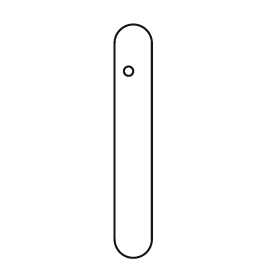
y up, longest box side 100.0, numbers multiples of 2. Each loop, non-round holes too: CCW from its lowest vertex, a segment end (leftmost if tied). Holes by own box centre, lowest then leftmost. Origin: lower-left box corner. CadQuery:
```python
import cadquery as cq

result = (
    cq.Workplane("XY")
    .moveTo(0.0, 8.0)
    .threePointArc((8.0, 0.0), (16.0, 8.0))
    .lineTo(16.0, 92.0)
    .threePointArc((8.0, 100.0), (0.0, 92.0))
    .close()
    .moveTo(6.0, 80.0)
    .circle(2.0)
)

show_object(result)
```